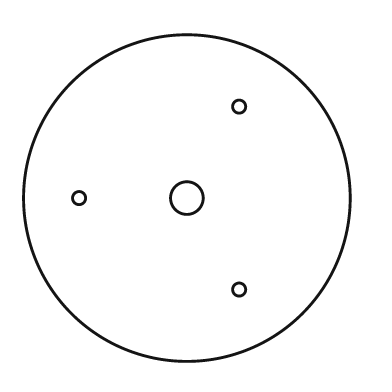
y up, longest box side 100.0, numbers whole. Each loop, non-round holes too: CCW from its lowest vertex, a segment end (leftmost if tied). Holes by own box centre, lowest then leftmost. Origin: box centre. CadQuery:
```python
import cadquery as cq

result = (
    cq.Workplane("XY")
    .moveTo(0.0, 0.0)
    .circle(50.0)
    .moveTo(16.0, -28.0)
    .circle(2.0)
    .moveTo(-33.0, 0.0)
    .circle(2.0)
    .moveTo(0.0, 0.0)
    .circle(5.0)
    .moveTo(16.0, 28.0)
    .circle(2.0)
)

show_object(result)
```